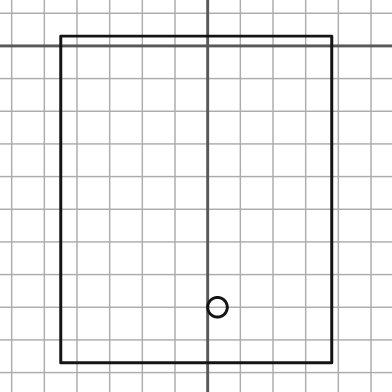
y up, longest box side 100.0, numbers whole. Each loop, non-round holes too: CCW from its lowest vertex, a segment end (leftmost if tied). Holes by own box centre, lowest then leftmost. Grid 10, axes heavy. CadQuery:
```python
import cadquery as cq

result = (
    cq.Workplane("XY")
    .moveTo(-45.0, -97.0)
    .lineTo(38.0, -97.0)
    .lineTo(38.0, 3.0)
    .lineTo(-45.0, 3.0)
    .close()
    .moveTo(3.0, -80.0)
    .circle(3.0)
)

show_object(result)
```